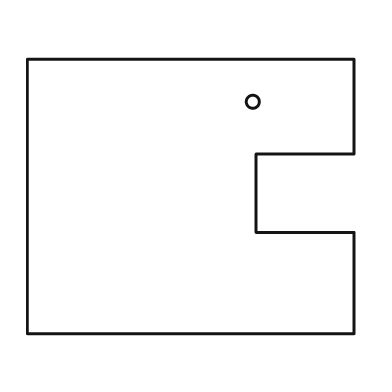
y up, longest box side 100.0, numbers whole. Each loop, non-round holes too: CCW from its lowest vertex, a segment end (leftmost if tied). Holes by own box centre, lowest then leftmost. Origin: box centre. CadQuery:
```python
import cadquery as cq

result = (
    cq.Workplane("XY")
    .moveTo(-50.0, -42.0)
    .lineTo(50.0, -42.0)
    .lineTo(50.0, -11.0)
    .lineTo(20.0, -11.0)
    .lineTo(20.0, 13.0)
    .lineTo(50.0, 13.0)
    .lineTo(50.0, 42.0)
    .lineTo(-50.0, 42.0)
    .close()
    .moveTo(19.0, 29.0)
    .circle(2.0)
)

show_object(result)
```